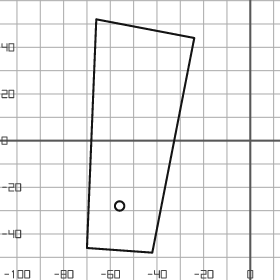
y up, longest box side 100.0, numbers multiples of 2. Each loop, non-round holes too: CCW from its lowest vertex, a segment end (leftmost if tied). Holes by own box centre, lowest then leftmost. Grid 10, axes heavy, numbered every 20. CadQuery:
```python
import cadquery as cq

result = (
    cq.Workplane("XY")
    .moveTo(-42.0, -48.0)
    .lineTo(-24.0, 44.0)
    .lineTo(-66.0, 52.0)
    .lineTo(-70.0, -46.0)
    .close()
    .moveTo(-56.0, -28.0)
    .circle(2.0)
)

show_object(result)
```